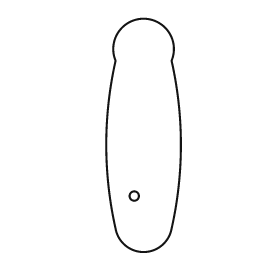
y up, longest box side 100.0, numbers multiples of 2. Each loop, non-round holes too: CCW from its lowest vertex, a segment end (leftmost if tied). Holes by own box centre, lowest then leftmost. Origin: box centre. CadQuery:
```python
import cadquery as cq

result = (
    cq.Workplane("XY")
    .moveTo(-12.0, -40.0)
    .threePointArc((0.0, -50.0), (12.0, -40.0))
    .threePointArc((16.0, -4.0), (12.0, 32.0))
    .threePointArc((0.0, 50.0), (-12.0, 32.0))
    .threePointArc((-16.0, -4.0), (-12.0, -40.0))
    .close()
    .moveTo(-4.0, -26.0)
    .circle(2.0)
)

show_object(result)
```